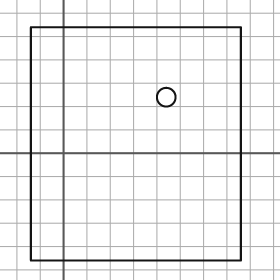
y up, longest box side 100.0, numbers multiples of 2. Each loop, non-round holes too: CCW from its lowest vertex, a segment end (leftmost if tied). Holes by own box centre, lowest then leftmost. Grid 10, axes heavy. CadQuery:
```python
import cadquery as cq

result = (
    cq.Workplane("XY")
    .moveTo(-14.0, -46.0)
    .lineTo(76.0, -46.0)
    .lineTo(76.0, 54.0)
    .lineTo(-14.0, 54.0)
    .close()
    .moveTo(44.0, 24.0)
    .circle(4.0)
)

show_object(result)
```